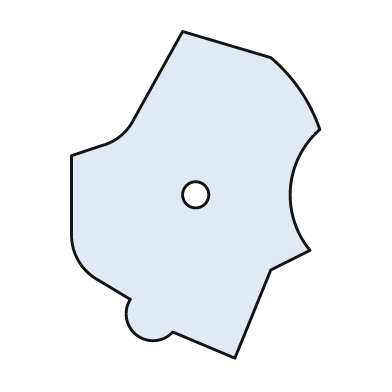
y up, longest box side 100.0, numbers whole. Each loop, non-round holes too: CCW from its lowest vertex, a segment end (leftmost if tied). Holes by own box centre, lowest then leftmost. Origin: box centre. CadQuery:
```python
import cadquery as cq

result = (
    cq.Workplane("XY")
    .moveTo(12.0, -50.0)
    .lineTo(23.0, -23.0)
    .lineTo(35.0, -17.0)
    .threePointArc((29.0, 2.0), (38.0, 20.0))
    .threePointArc((32.0, 32.0), (23.0, 42.0))
    .lineTo(-4.0, 50.0)
    .lineTo(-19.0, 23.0)
    .threePointArc((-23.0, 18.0), (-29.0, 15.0))
    .lineTo(-38.0, 12.0)
    .lineTo(-38.0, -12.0)
    .threePointArc((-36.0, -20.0), (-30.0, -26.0))
    .lineTo(-20.0, -32.0)
    .threePointArc((-18.0, -43.0), (-7.0, -42.0))
    .close()
    .moveTo(0.0, 0.0)
    .circle(4.0)
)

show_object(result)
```